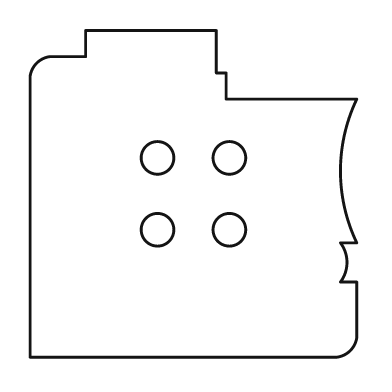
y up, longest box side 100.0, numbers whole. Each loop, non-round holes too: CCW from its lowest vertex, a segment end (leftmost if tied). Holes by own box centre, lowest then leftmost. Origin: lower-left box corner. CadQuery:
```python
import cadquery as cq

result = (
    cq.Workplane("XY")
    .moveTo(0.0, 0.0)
    .lineTo(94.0, 0.0)
    .threePointArc((98.0, 2.0), (100.0, 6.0))
    .lineTo(100.0, 23.0)
    .lineTo(95.0, 23.0)
    .threePointArc((97.0, 29.0), (95.0, 35.0))
    .lineTo(100.0, 35.0)
    .threePointArc((95.0, 57.0), (100.0, 79.0))
    .lineTo(60.0, 79.0)
    .lineTo(60.0, 87.0)
    .lineTo(57.0, 87.0)
    .lineTo(57.0, 100.0)
    .lineTo(17.0, 100.0)
    .lineTo(17.0, 92.0)
    .lineTo(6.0, 92.0)
    .threePointArc((2.0, 90.0), (0.0, 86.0))
    .close()
    .moveTo(39.0, 39.0)
    .circle(5.0)
    .moveTo(61.0, 39.0)
    .circle(5.0)
    .moveTo(39.0, 61.0)
    .circle(5.0)
    .moveTo(61.0, 61.0)
    .circle(5.0)
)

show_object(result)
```